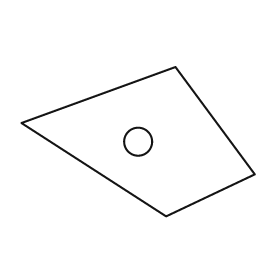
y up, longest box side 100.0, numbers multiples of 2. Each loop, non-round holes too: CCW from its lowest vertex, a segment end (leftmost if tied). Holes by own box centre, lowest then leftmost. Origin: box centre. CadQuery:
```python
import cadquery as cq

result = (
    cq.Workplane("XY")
    .moveTo(12.0, -32.0)
    .lineTo(50.0, -14.0)
    .lineTo(16.0, 32.0)
    .lineTo(-50.0, 8.0)
    .close()
    .moveTo(0.0, 0.0)
    .circle(6.0)
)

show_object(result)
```